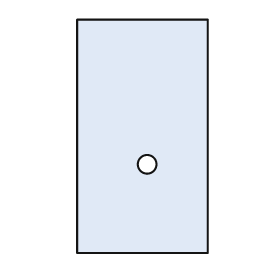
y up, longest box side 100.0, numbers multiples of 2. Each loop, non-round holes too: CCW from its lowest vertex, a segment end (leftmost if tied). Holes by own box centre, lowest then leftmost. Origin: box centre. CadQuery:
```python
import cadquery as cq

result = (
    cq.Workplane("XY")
    .moveTo(-28.0, -50.0)
    .lineTo(28.0, -50.0)
    .lineTo(28.0, 50.0)
    .lineTo(-28.0, 50.0)
    .close()
    .moveTo(2.0, -12.0)
    .circle(4.0)
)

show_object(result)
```